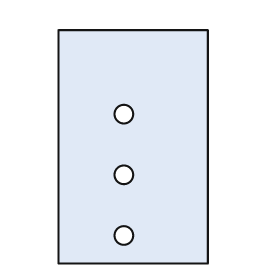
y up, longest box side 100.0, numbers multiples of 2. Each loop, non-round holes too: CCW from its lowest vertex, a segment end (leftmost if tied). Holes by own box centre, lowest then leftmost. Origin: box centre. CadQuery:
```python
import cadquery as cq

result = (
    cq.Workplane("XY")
    .moveTo(-32.0, -50.0)
    .lineTo(32.0, -50.0)
    .lineTo(32.0, 50.0)
    .lineTo(-32.0, 50.0)
    .close()
    .moveTo(-4.0, -38.0)
    .circle(4.0)
    .moveTo(-4.0, -12.0)
    .circle(4.0)
    .moveTo(-4.0, 14.0)
    .circle(4.0)
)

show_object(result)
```